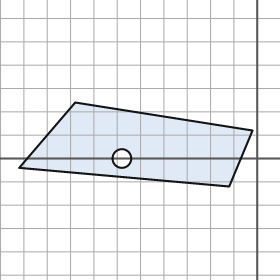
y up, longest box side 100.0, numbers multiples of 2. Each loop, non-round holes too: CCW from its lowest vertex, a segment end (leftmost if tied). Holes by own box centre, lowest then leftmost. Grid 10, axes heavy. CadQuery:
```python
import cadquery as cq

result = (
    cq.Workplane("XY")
    .moveTo(-12.0, -12.0)
    .lineTo(-2.0, 12.0)
    .lineTo(-78.0, 24.0)
    .lineTo(-102.0, -4.0)
    .close()
    .moveTo(-58.0, 0.0)
    .circle(4.0)
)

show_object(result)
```